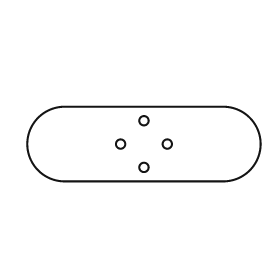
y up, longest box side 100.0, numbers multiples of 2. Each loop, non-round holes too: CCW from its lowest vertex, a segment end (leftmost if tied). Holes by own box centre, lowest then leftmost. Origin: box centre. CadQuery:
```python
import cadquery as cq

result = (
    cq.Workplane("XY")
    .moveTo(-34.0, -16.0)
    .lineTo(34.0, -16.0)
    .threePointArc((50.0, 0.0), (34.0, 16.0))
    .lineTo(-34.0, 16.0)
    .threePointArc((-50.0, 0.0), (-34.0, -16.0))
    .close()
    .moveTo(0.0, -10.0)
    .circle(2.0)
    .moveTo(-10.0, 0.0)
    .circle(2.0)
    .moveTo(10.0, 0.0)
    .circle(2.0)
    .moveTo(0.0, 10.0)
    .circle(2.0)
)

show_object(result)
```